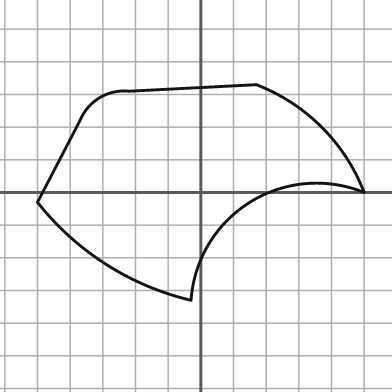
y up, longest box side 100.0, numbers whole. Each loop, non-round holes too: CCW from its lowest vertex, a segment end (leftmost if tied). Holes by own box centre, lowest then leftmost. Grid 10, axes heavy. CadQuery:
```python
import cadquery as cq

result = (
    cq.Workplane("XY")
    .moveTo(-3.0, -33.0)
    .threePointArc((15.0, -3.0), (50.0, 0.0))
    .threePointArc((37.0, 20.0), (17.0, 33.0))
    .lineTo(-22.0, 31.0)
    .threePointArc((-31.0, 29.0), (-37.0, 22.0))
    .lineTo(-50.0, -3.0)
    .threePointArc((-29.0, -22.0), (-3.0, -33.0))
    .close()
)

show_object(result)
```